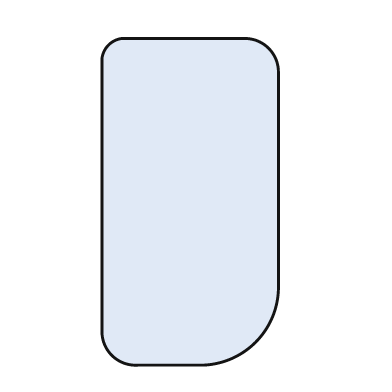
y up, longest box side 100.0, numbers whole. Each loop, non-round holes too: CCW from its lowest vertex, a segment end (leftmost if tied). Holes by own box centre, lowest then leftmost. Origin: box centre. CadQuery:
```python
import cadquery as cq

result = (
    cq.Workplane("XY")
    .moveTo(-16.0, -50.0)
    .lineTo(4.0, -50.0)
    .threePointArc((20.0, -43.0), (27.0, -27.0))
    .lineTo(27.0, 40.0)
    .threePointArc((24.0, 47.0), (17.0, 50.0))
    .lineTo(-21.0, 50.0)
    .threePointArc((-25.0, 48.0), (-27.0, 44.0))
    .lineTo(-27.0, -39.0)
    .threePointArc((-24.0, -47.0), (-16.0, -50.0))
    .close()
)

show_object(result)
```